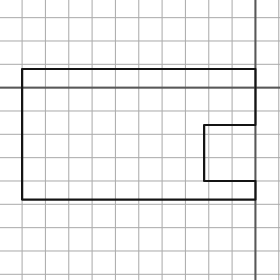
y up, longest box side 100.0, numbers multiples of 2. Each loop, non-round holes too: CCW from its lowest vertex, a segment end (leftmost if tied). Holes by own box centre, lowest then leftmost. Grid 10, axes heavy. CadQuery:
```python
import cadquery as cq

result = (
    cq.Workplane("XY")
    .moveTo(-100.0, -48.0)
    .lineTo(0.0, -48.0)
    .lineTo(0.0, -40.0)
    .lineTo(-22.0, -40.0)
    .lineTo(-22.0, -16.0)
    .lineTo(0.0, -16.0)
    .lineTo(0.0, 8.0)
    .lineTo(-100.0, 8.0)
    .close()
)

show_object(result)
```